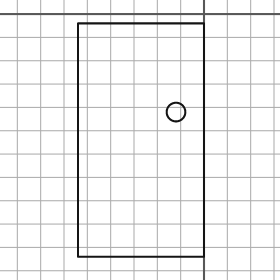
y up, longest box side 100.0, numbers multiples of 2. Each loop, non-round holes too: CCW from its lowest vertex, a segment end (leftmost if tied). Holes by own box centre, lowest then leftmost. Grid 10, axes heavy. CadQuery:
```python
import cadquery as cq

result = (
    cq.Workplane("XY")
    .moveTo(-54.0, -104.0)
    .lineTo(0.0, -104.0)
    .lineTo(0.0, -4.0)
    .lineTo(-54.0, -4.0)
    .close()
    .moveTo(-12.0, -42.0)
    .circle(4.0)
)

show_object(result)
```